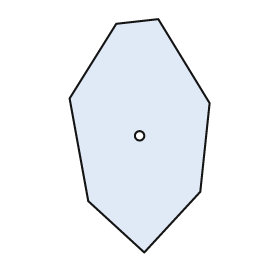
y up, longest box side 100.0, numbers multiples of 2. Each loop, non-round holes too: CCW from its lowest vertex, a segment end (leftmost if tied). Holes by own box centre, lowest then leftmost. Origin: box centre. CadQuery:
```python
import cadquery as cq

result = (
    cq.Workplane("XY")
    .moveTo(2.0, -50.0)
    .lineTo(26.0, -24.0)
    .lineTo(30.0, 14.0)
    .lineTo(8.0, 50.0)
    .lineTo(-10.0, 48.0)
    .lineTo(-30.0, 16.0)
    .lineTo(-22.0, -28.0)
    .close()
    .moveTo(0.0, 0.0)
    .circle(2.0)
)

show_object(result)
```